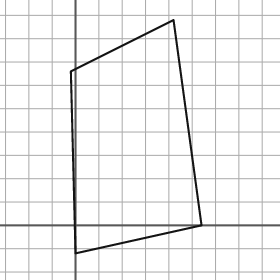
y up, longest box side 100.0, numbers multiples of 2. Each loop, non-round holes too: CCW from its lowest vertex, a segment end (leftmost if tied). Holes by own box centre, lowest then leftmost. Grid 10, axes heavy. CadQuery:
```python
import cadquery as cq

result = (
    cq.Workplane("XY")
    .moveTo(0.0, -12.0)
    .lineTo(54.0, 0.0)
    .lineTo(42.0, 88.0)
    .lineTo(-2.0, 66.0)
    .close()
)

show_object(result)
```